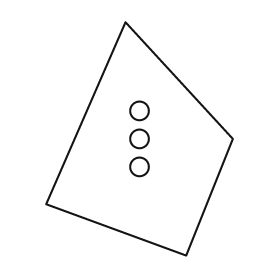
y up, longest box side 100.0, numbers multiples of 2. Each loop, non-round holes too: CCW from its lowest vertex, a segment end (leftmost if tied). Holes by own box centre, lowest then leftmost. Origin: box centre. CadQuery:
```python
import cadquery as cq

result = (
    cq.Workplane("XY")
    .moveTo(20.0, -50.0)
    .lineTo(40.0, 0.0)
    .lineTo(-6.0, 50.0)
    .lineTo(-40.0, -28.0)
    .close()
    .moveTo(0.0, -12.0)
    .circle(4.0)
    .moveTo(0.0, 0.0)
    .circle(4.0)
    .moveTo(0.0, 12.0)
    .circle(4.0)
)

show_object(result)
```